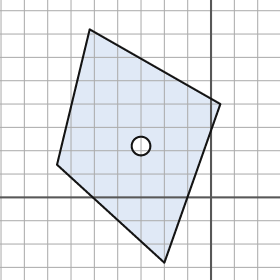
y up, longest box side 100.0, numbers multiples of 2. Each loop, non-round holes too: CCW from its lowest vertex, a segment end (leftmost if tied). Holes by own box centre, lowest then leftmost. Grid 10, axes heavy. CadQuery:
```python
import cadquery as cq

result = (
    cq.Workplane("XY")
    .moveTo(-20.0, -28.0)
    .lineTo(4.0, 40.0)
    .lineTo(-52.0, 72.0)
    .lineTo(-66.0, 14.0)
    .close()
    .moveTo(-30.0, 22.0)
    .circle(4.0)
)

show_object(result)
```